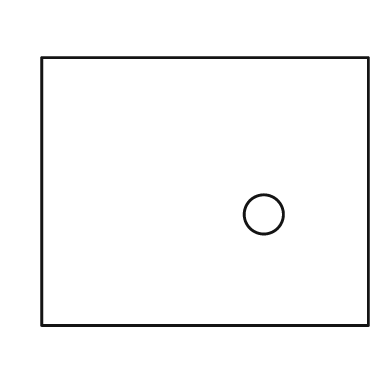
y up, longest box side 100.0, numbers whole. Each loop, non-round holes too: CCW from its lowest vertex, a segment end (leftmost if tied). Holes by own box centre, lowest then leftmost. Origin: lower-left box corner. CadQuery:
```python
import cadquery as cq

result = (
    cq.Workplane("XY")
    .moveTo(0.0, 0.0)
    .lineTo(100.0, 0.0)
    .lineTo(100.0, 82.0)
    .lineTo(0.0, 82.0)
    .close()
    .moveTo(68.0, 34.0)
    .circle(6.0)
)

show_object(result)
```